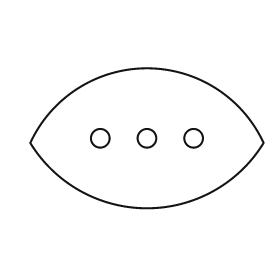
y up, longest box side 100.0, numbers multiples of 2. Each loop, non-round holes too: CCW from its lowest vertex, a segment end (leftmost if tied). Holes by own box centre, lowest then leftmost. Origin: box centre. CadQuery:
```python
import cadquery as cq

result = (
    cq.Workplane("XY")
    .moveTo(-50.0, -2.0)
    .threePointArc((0.0, -30.0), (50.0, -2.0))
    .threePointArc((0.0, 30.0), (-50.0, -2.0))
    .close()
    .moveTo(-20.0, 0.0)
    .circle(4.0)
    .moveTo(0.0, 0.0)
    .circle(4.0)
    .moveTo(20.0, 0.0)
    .circle(4.0)
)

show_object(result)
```